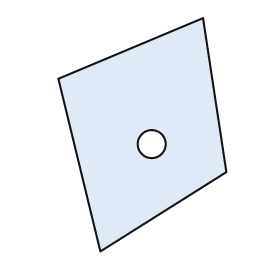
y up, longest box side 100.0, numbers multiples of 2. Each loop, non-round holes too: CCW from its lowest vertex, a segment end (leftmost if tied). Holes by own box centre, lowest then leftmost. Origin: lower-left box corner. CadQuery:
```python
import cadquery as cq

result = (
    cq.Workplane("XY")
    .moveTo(18.0, 0.0)
    .lineTo(72.0, 34.0)
    .lineTo(62.0, 100.0)
    .lineTo(0.0, 74.0)
    .close()
    .moveTo(40.0, 46.0)
    .circle(6.0)
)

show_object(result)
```